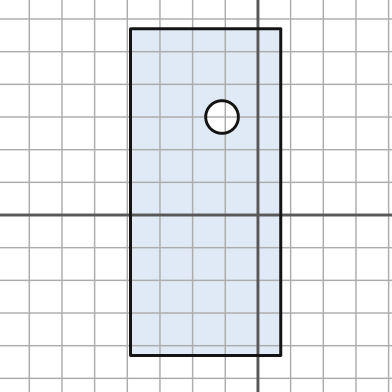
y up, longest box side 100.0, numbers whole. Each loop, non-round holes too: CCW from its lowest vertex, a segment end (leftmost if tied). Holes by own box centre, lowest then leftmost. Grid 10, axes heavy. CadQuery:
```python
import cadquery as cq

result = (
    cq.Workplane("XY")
    .moveTo(-39.0, -43.0)
    .lineTo(7.0, -43.0)
    .lineTo(7.0, 57.0)
    .lineTo(-39.0, 57.0)
    .close()
    .moveTo(-11.0, 30.0)
    .circle(5.0)
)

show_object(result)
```